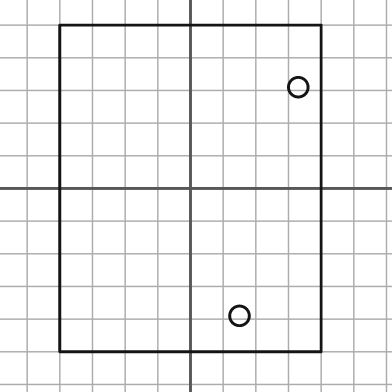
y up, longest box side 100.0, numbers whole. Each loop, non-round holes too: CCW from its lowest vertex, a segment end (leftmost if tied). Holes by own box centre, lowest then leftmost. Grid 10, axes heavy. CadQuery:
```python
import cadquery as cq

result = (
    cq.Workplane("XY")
    .moveTo(-40.0, -50.0)
    .lineTo(40.0, -50.0)
    .lineTo(40.0, 50.0)
    .lineTo(-40.0, 50.0)
    .close()
    .moveTo(15.0, -39.0)
    .circle(3.0)
    .moveTo(33.0, 31.0)
    .circle(3.0)
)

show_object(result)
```